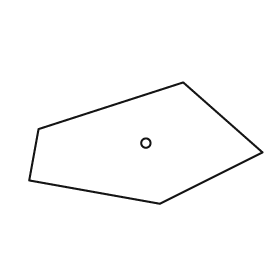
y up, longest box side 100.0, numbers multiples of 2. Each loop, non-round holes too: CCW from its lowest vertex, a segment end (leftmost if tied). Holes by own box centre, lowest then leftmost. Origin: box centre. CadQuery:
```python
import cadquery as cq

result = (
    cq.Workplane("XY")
    .moveTo(6.0, -26.0)
    .lineTo(50.0, -4.0)
    .lineTo(16.0, 26.0)
    .lineTo(-46.0, 6.0)
    .lineTo(-50.0, -16.0)
    .close()
    .moveTo(0.0, 0.0)
    .circle(2.0)
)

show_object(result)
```